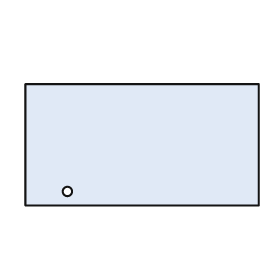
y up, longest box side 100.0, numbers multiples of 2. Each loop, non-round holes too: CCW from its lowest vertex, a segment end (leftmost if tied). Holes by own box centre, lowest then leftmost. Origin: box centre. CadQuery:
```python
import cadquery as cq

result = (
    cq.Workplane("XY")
    .moveTo(-50.0, -26.0)
    .lineTo(50.0, -26.0)
    .lineTo(50.0, 26.0)
    .lineTo(-50.0, 26.0)
    .close()
    .moveTo(-32.0, -20.0)
    .circle(2.0)
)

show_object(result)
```